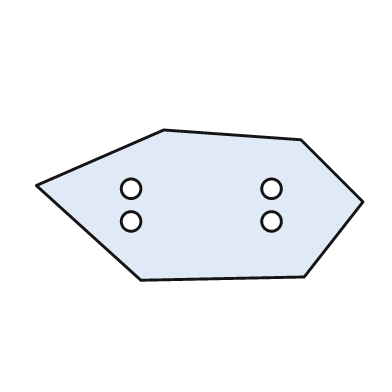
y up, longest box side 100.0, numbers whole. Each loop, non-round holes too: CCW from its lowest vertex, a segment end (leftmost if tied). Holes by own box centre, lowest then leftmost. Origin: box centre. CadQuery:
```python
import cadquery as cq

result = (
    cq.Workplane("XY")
    .moveTo(-18.0, -23.0)
    .lineTo(32.0, -22.0)
    .lineTo(50.0, 1.0)
    .lineTo(31.0, 20.0)
    .lineTo(-11.0, 23.0)
    .lineTo(-50.0, 6.0)
    .close()
    .moveTo(-21.0, -5.0)
    .circle(3.0)
    .moveTo(22.0, -5.0)
    .circle(3.0)
    .moveTo(-21.0, 5.0)
    .circle(3.0)
    .moveTo(22.0, 5.0)
    .circle(3.0)
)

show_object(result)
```